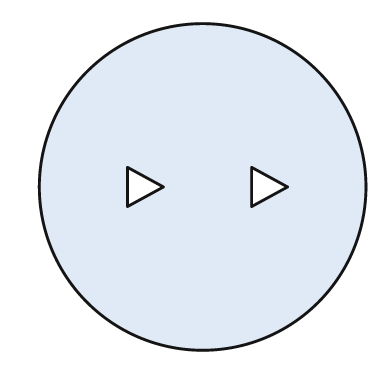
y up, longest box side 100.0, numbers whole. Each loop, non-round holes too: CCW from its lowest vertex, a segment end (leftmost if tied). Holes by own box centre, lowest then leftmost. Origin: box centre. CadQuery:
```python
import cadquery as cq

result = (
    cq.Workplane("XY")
    .moveTo(0.0, 0.0)
    .circle(50.0)
    .moveTo(-23.0, -6.0)
    .lineTo(-12.0, 0.0)
    .lineTo(-23.0, 6.0)
    .close()
    .moveTo(15.0, -6.0)
    .lineTo(26.0, 0.0)
    .lineTo(15.0, 6.0)
    .close()
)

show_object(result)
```